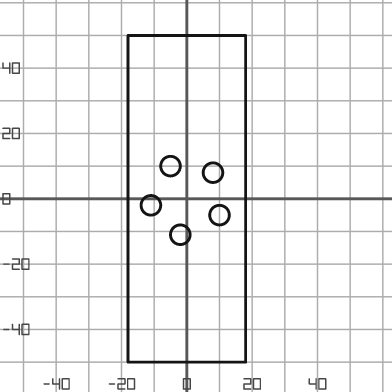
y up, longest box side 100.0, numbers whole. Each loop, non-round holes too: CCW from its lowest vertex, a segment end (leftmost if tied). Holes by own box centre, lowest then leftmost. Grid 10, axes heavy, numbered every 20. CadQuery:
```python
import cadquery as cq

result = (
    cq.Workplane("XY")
    .moveTo(-18.0, -50.0)
    .lineTo(18.0, -50.0)
    .lineTo(18.0, 50.0)
    .lineTo(-18.0, 50.0)
    .close()
    .moveTo(-2.0, -11.0)
    .circle(3.0)
    .moveTo(10.0, -5.0)
    .circle(3.0)
    .moveTo(-11.0, -2.0)
    .circle(3.0)
    .moveTo(8.0, 8.0)
    .circle(3.0)
    .moveTo(-5.0, 10.0)
    .circle(3.0)
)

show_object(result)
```